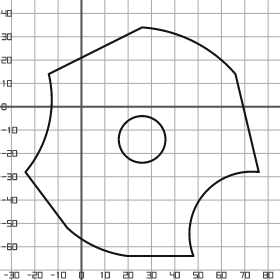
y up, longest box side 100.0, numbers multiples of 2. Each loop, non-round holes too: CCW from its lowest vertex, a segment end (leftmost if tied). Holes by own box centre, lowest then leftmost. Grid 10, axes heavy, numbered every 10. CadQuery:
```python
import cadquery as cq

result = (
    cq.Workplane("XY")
    .moveTo(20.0, -64.0)
    .lineTo(48.0, -64.0)
    .threePointArc((52.0, -38.0), (76.0, -28.0))
    .lineTo(66.0, 14.0)
    .threePointArc((48.0, 28.0), (26.0, 34.0))
    .lineTo(-14.0, 14.0)
    .threePointArc((-14.0, -8.0), (-24.0, -28.0))
    .lineTo(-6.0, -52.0)
    .threePointArc((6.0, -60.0), (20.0, -64.0))
    .close()
    .moveTo(26.0, -14.0)
    .circle(10.0)
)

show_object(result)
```